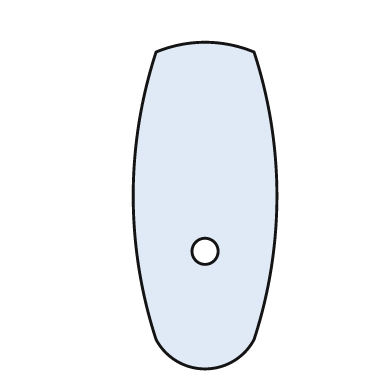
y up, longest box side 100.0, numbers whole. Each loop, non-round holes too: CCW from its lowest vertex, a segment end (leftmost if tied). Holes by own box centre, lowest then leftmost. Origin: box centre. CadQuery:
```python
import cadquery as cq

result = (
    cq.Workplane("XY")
    .moveTo(-15.0, -41.0)
    .threePointArc((0.0, -50.0), (15.0, -41.0))
    .threePointArc((22.0, 3.0), (15.0, 47.0))
    .threePointArc((0.0, 50.0), (-15.0, 47.0))
    .threePointArc((-22.0, 3.0), (-15.0, -41.0))
    .close()
    .moveTo(0.0, -14.0)
    .circle(4.0)
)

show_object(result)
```